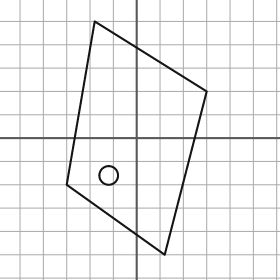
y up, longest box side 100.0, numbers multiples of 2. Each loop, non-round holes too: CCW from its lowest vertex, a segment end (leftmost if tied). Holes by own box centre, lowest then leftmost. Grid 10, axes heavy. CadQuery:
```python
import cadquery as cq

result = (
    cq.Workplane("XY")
    .moveTo(12.0, -50.0)
    .lineTo(30.0, 20.0)
    .lineTo(-18.0, 50.0)
    .lineTo(-30.0, -20.0)
    .close()
    .moveTo(-12.0, -16.0)
    .circle(4.0)
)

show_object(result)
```